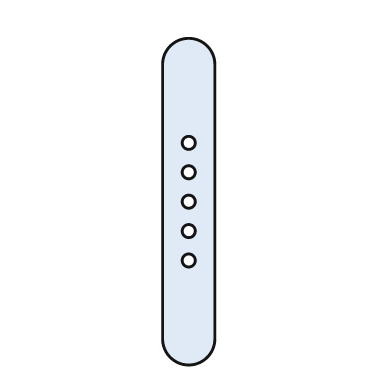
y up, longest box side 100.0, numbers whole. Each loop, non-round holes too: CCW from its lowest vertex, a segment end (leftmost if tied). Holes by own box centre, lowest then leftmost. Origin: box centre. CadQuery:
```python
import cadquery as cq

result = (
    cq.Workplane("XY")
    .moveTo(-8.0, -42.0)
    .threePointArc((0.0, -50.0), (8.0, -42.0))
    .lineTo(8.0, 42.0)
    .threePointArc((0.0, 50.0), (-8.0, 42.0))
    .close()
    .moveTo(0.0, -18.0)
    .circle(2.0)
    .moveTo(0.0, -9.0)
    .circle(2.0)
    .moveTo(0.0, 0.0)
    .circle(2.0)
    .moveTo(0.0, 9.0)
    .circle(2.0)
    .moveTo(0.0, 18.0)
    .circle(2.0)
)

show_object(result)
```